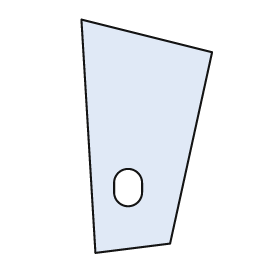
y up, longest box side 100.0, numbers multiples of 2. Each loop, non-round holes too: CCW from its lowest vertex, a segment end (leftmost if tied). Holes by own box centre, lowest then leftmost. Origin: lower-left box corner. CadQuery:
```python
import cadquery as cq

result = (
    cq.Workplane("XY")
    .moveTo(6.0, 0.0)
    .lineTo(38.0, 4.0)
    .lineTo(56.0, 86.0)
    .lineTo(0.0, 100.0)
    .close()
    .moveTo(14.0, 26.0)
    .threePointArc((20.0, 20.0), (26.0, 26.0))
    .lineTo(26.0, 30.0)
    .threePointArc((20.0, 36.0), (14.0, 30.0))
    .close()
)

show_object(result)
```